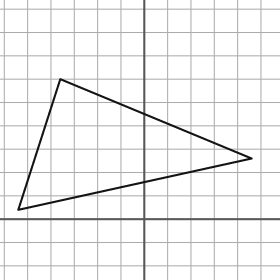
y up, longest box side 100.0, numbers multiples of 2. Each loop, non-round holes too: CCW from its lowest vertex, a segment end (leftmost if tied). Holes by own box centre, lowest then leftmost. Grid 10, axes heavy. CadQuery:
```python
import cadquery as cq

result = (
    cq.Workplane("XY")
    .moveTo(-54.0, 4.0)
    .lineTo(46.0, 26.0)
    .lineTo(-36.0, 60.0)
    .close()
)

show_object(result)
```